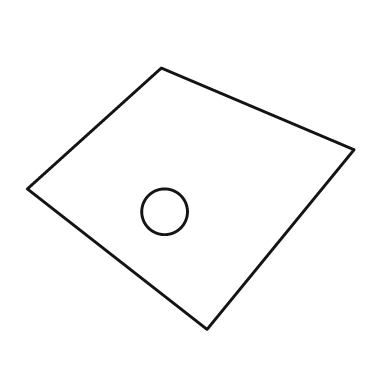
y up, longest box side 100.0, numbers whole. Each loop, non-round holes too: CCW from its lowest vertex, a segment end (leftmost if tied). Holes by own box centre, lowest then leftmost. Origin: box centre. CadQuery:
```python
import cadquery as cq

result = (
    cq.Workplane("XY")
    .moveTo(5.0, -40.0)
    .lineTo(50.0, 15.0)
    .lineTo(-9.0, 40.0)
    .lineTo(-50.0, 3.0)
    .close()
    .moveTo(-8.0, -4.0)
    .circle(7.0)
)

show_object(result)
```